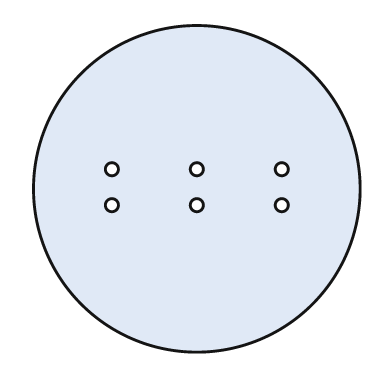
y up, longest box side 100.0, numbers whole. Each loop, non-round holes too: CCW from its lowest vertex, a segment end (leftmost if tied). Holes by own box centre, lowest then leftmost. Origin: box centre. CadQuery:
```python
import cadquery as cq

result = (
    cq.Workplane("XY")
    .moveTo(0.0, 0.0)
    .circle(50.0)
    .moveTo(-26.0, -5.0)
    .circle(2.0)
    .moveTo(0.0, -5.0)
    .circle(2.0)
    .moveTo(26.0, -5.0)
    .circle(2.0)
    .moveTo(-26.0, 6.0)
    .circle(2.0)
    .moveTo(0.0, 6.0)
    .circle(2.0)
    .moveTo(26.0, 6.0)
    .circle(2.0)
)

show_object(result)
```